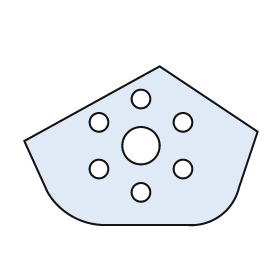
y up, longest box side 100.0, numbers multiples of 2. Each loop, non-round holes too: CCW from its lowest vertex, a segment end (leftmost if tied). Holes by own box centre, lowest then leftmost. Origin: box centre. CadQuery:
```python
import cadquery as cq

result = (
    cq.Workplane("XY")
    .moveTo(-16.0, -34.0)
    .lineTo(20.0, -34.0)
    .threePointArc((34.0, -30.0), (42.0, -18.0))
    .lineTo(50.0, 6.0)
    .lineTo(8.0, 34.0)
    .lineTo(-50.0, 2.0)
    .lineTo(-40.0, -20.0)
    .threePointArc((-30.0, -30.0), (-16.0, -34.0))
    .close()
    .moveTo(0.0, -20.0)
    .circle(4.0)
    .moveTo(-18.0, -10.0)
    .circle(4.0)
    .moveTo(18.0, -10.0)
    .circle(4.0)
    .moveTo(0.0, 0.0)
    .circle(8.0)
    .moveTo(-18.0, 10.0)
    .circle(4.0)
    .moveTo(18.0, 10.0)
    .circle(4.0)
    .moveTo(0.0, 20.0)
    .circle(4.0)
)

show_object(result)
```